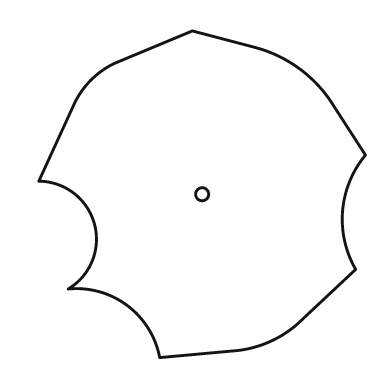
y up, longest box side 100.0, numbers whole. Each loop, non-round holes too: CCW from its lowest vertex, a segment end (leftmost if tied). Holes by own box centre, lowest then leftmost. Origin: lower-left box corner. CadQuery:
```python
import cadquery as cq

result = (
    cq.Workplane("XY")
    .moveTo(37.0, 0.0)
    .lineTo(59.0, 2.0)
    .threePointArc((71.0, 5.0), (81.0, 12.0))
    .lineTo(97.0, 27.0)
    .threePointArc((93.0, 45.0), (100.0, 62.0))
    .lineTo(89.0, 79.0)
    .threePointArc((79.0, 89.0), (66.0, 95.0))
    .lineTo(47.0, 100.0)
    .lineTo(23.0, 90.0)
    .threePointArc((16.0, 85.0), (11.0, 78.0))
    .lineTo(0.0, 54.0)
    .threePointArc((17.0, 41.0), (9.0, 21.0))
    .threePointArc((27.0, 16.0), (37.0, 0.0))
    .close()
    .moveTo(50.0, 50.0)
    .circle(2.0)
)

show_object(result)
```